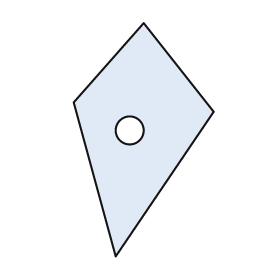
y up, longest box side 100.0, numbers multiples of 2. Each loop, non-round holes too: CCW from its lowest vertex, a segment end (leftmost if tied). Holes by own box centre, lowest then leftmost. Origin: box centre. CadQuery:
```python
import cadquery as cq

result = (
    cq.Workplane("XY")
    .moveTo(-12.0, -50.0)
    .lineTo(30.0, 12.0)
    .lineTo(0.0, 50.0)
    .lineTo(-30.0, 16.0)
    .close()
    .moveTo(-6.0, 4.0)
    .circle(6.0)
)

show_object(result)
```